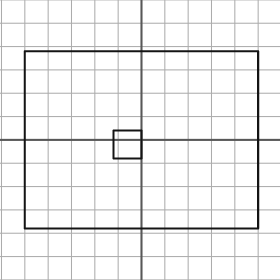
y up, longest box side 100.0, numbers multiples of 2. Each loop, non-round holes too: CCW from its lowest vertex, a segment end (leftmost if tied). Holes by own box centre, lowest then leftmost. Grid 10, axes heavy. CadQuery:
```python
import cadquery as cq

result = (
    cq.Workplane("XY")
    .moveTo(-50.0, -38.0)
    .lineTo(50.0, -38.0)
    .lineTo(50.0, 38.0)
    .lineTo(-50.0, 38.0)
    .close()
    .moveTo(-12.0, -8.0)
    .lineTo(0.0, -8.0)
    .lineTo(0.0, 4.0)
    .lineTo(-12.0, 4.0)
    .close()
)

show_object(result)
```